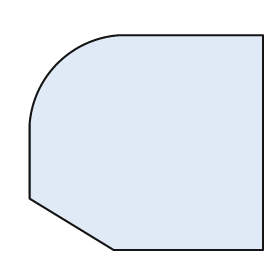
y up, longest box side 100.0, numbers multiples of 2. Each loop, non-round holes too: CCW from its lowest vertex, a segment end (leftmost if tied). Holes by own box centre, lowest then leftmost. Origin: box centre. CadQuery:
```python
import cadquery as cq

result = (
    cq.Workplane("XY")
    .moveTo(-14.0, -46.0)
    .lineTo(50.0, -46.0)
    .lineTo(50.0, 46.0)
    .lineTo(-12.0, 46.0)
    .threePointArc((-38.0, 34.0), (-50.0, 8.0))
    .lineTo(-50.0, -24.0)
    .close()
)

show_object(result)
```